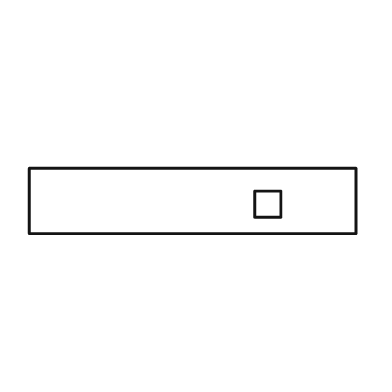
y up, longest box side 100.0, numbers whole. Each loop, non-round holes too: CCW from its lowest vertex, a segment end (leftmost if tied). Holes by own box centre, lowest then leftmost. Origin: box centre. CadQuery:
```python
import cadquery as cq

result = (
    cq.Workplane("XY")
    .moveTo(-50.0, -10.0)
    .lineTo(50.0, -10.0)
    .lineTo(50.0, 10.0)
    .lineTo(-50.0, 10.0)
    .close()
    .moveTo(19.0, -5.0)
    .lineTo(27.0, -5.0)
    .lineTo(27.0, 3.0)
    .lineTo(19.0, 3.0)
    .close()
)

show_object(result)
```